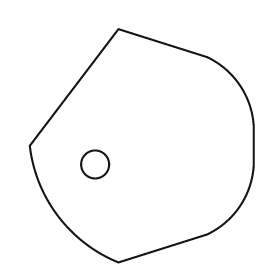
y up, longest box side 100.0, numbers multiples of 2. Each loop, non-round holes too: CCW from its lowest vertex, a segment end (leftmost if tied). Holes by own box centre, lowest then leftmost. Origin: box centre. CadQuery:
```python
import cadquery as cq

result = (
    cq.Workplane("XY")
    .moveTo(-10.0, -50.0)
    .lineTo(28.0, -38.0)
    .threePointArc((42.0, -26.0), (48.0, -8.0))
    .lineTo(48.0, 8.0)
    .threePointArc((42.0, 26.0), (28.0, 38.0))
    .lineTo(-10.0, 50.0)
    .lineTo(-48.0, 0.0)
    .threePointArc((-36.0, -30.0), (-10.0, -50.0))
    .close()
    .moveTo(-20.0, -8.0)
    .circle(6.0)
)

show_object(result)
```